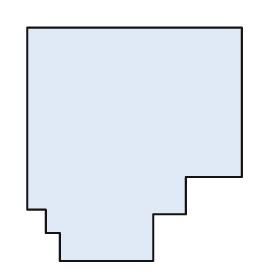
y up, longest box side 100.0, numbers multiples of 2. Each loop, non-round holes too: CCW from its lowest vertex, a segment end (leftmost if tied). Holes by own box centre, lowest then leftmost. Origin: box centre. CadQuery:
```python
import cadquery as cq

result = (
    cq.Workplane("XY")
    .moveTo(-32.0, -50.0)
    .lineTo(8.0, -50.0)
    .lineTo(8.0, -30.0)
    .lineTo(22.0, -30.0)
    .lineTo(22.0, -14.0)
    .lineTo(46.0, -14.0)
    .lineTo(46.0, 50.0)
    .lineTo(-46.0, 50.0)
    .lineTo(-46.0, -28.0)
    .lineTo(-38.0, -28.0)
    .lineTo(-38.0, -38.0)
    .lineTo(-32.0, -38.0)
    .close()
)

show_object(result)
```